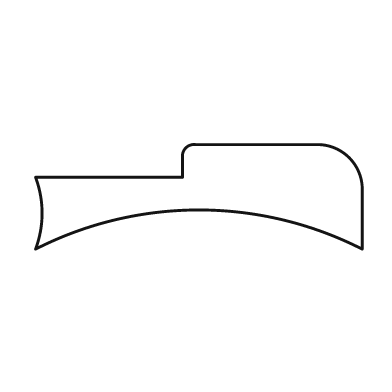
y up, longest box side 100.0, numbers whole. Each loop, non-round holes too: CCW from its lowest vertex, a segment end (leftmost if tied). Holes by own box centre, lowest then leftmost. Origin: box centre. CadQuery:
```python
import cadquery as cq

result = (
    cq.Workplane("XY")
    .moveTo(-50.0, -16.0)
    .threePointArc((0.0, -4.0), (50.0, -16.0))
    .lineTo(50.0, 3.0)
    .threePointArc((46.0, 12.0), (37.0, 16.0))
    .lineTo(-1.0, 16.0)
    .threePointArc((-4.0, 15.0), (-5.0, 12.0))
    .lineTo(-5.0, 6.0)
    .lineTo(-50.0, 6.0)
    .threePointArc((-48.0, -5.0), (-50.0, -16.0))
    .close()
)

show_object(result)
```